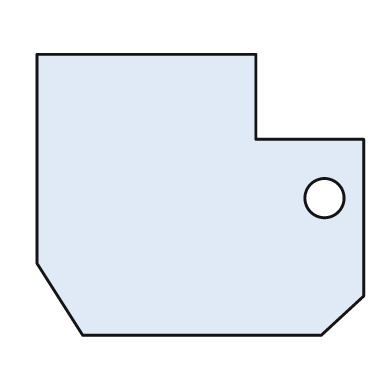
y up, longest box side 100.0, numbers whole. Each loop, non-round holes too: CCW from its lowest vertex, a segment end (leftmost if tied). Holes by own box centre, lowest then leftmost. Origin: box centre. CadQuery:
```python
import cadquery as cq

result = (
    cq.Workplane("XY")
    .moveTo(-36.0, -43.0)
    .lineTo(37.0, -43.0)
    .lineTo(50.0, -31.0)
    .lineTo(50.0, 17.0)
    .lineTo(17.0, 17.0)
    .lineTo(17.0, 43.0)
    .lineTo(-50.0, 43.0)
    .lineTo(-50.0, -21.0)
    .close()
    .moveTo(38.0, -1.0)
    .circle(6.0)
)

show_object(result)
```